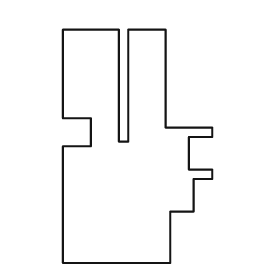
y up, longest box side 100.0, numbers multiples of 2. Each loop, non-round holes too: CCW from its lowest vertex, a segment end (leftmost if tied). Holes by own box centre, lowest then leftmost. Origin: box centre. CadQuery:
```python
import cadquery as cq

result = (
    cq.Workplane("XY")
    .moveTo(-32.0, -50.0)
    .lineTo(14.0, -50.0)
    .lineTo(14.0, -28.0)
    .lineTo(24.0, -28.0)
    .lineTo(24.0, -14.0)
    .lineTo(32.0, -14.0)
    .lineTo(32.0, -10.0)
    .lineTo(22.0, -10.0)
    .lineTo(22.0, 4.0)
    .lineTo(32.0, 4.0)
    .lineTo(32.0, 8.0)
    .lineTo(12.0, 8.0)
    .lineTo(12.0, 50.0)
    .lineTo(-4.0, 50.0)
    .lineTo(-4.0, 2.0)
    .lineTo(-8.0, 2.0)
    .lineTo(-8.0, 50.0)
    .lineTo(-32.0, 50.0)
    .lineTo(-32.0, 12.0)
    .lineTo(-20.0, 12.0)
    .lineTo(-20.0, 0.0)
    .lineTo(-32.0, 0.0)
    .close()
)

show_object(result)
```